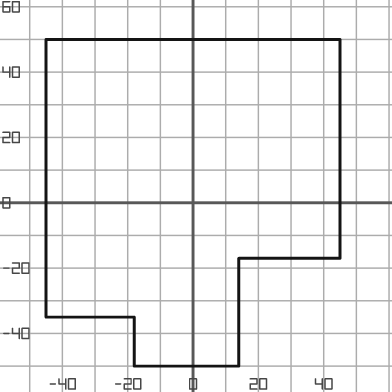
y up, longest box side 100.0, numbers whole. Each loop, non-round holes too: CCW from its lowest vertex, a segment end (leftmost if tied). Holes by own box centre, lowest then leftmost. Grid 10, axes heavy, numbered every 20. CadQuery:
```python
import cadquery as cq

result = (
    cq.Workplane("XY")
    .moveTo(-18.0, -50.0)
    .lineTo(14.0, -50.0)
    .lineTo(14.0, -17.0)
    .lineTo(45.0, -17.0)
    .lineTo(45.0, 50.0)
    .lineTo(-45.0, 50.0)
    .lineTo(-45.0, -35.0)
    .lineTo(-18.0, -35.0)
    .close()
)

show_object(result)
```